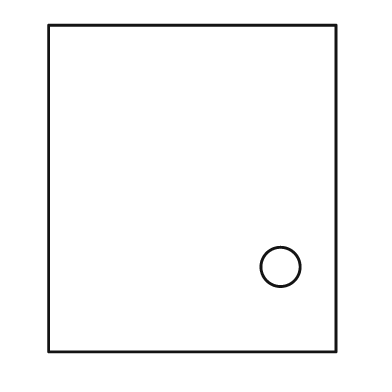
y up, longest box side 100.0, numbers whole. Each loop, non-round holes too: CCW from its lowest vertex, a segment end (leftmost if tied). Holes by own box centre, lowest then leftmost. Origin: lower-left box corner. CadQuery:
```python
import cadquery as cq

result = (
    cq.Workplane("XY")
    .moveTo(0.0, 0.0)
    .lineTo(88.0, 0.0)
    .lineTo(88.0, 100.0)
    .lineTo(0.0, 100.0)
    .close()
    .moveTo(71.0, 26.0)
    .circle(6.0)
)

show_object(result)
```